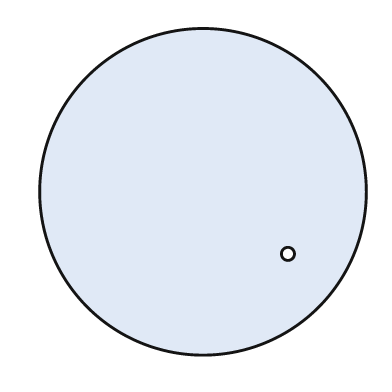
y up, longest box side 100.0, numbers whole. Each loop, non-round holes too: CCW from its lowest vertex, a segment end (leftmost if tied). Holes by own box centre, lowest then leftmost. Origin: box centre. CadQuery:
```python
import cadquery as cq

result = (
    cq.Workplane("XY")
    .moveTo(0.0, 0.0)
    .circle(50.0)
    .moveTo(26.0, -19.0)
    .circle(2.0)
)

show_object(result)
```